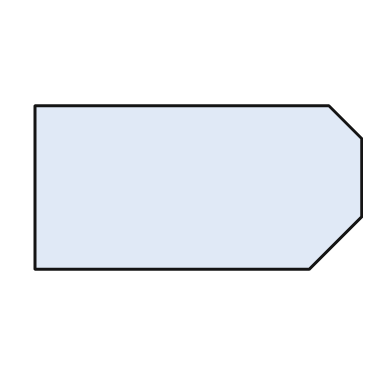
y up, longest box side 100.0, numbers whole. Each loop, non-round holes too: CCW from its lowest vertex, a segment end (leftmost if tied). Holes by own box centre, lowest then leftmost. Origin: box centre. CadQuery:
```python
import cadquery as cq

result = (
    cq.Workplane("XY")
    .moveTo(-50.0, -25.0)
    .lineTo(34.0, -25.0)
    .lineTo(50.0, -9.0)
    .lineTo(50.0, 15.0)
    .lineTo(40.0, 25.0)
    .lineTo(-50.0, 25.0)
    .close()
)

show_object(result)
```